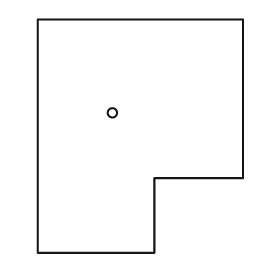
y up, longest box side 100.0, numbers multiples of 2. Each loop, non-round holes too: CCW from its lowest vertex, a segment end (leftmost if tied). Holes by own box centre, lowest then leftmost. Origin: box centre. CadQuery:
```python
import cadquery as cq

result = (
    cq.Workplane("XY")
    .moveTo(-44.0, -50.0)
    .lineTo(6.0, -50.0)
    .lineTo(6.0, -18.0)
    .lineTo(44.0, -18.0)
    .lineTo(44.0, 50.0)
    .lineTo(-44.0, 50.0)
    .close()
    .moveTo(-12.0, 10.0)
    .circle(2.0)
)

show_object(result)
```